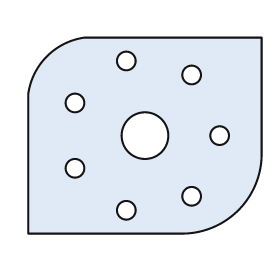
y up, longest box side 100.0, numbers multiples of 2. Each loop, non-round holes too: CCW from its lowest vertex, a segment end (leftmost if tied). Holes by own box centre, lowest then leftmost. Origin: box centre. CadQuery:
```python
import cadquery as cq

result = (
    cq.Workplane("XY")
    .moveTo(-50.0, -42.0)
    .lineTo(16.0, -42.0)
    .threePointArc((40.0, -32.0), (50.0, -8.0))
    .lineTo(50.0, 42.0)
    .lineTo(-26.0, 42.0)
    .threePointArc((-42.0, 34.0), (-50.0, 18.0))
    .close()
    .moveTo(-8.0, -32.0)
    .circle(4.0)
    .moveTo(20.0, -26.0)
    .circle(4.0)
    .moveTo(-30.0, -14.0)
    .circle(4.0)
    .moveTo(0.0, 0.0)
    .circle(10.0)
    .moveTo(32.0, 0.0)
    .circle(4.0)
    .moveTo(-30.0, 14.0)
    .circle(4.0)
    .moveTo(20.0, 26.0)
    .circle(4.0)
    .moveTo(-8.0, 32.0)
    .circle(4.0)
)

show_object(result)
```